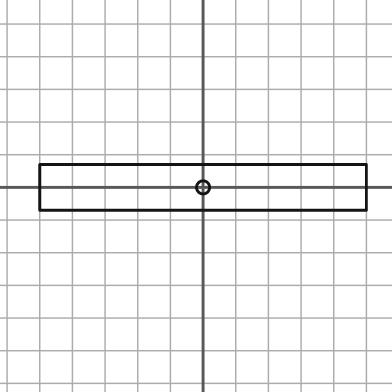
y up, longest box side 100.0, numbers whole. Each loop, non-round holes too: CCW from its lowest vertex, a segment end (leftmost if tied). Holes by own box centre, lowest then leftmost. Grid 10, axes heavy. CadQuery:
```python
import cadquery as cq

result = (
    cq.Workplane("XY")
    .moveTo(-50.0, -7.0)
    .lineTo(50.0, -7.0)
    .lineTo(50.0, 7.0)
    .lineTo(-50.0, 7.0)
    .close()
    .moveTo(0.0, 0.0)
    .circle(2.0)
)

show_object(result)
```